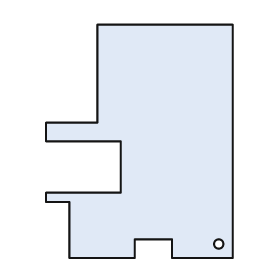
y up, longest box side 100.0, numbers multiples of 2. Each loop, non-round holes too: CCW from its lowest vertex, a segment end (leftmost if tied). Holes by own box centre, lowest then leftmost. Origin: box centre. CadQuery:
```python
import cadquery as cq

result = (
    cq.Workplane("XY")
    .moveTo(-30.0, -50.0)
    .lineTo(-2.0, -50.0)
    .lineTo(-2.0, -42.0)
    .lineTo(14.0, -42.0)
    .lineTo(14.0, -50.0)
    .lineTo(40.0, -50.0)
    .lineTo(40.0, 50.0)
    .lineTo(-18.0, 50.0)
    .lineTo(-18.0, 8.0)
    .lineTo(-40.0, 8.0)
    .lineTo(-40.0, 0.0)
    .lineTo(-8.0, 0.0)
    .lineTo(-8.0, -22.0)
    .lineTo(-40.0, -22.0)
    .lineTo(-40.0, -26.0)
    .lineTo(-30.0, -26.0)
    .close()
    .moveTo(34.0, -44.0)
    .circle(2.0)
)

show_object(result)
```